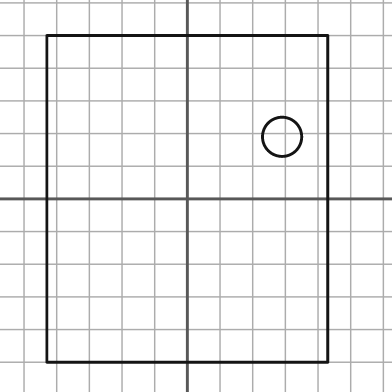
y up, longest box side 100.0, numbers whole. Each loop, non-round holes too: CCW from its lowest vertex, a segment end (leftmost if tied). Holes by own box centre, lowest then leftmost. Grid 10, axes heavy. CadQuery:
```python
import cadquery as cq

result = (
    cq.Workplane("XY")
    .moveTo(-43.0, -50.0)
    .lineTo(43.0, -50.0)
    .lineTo(43.0, 50.0)
    .lineTo(-43.0, 50.0)
    .close()
    .moveTo(29.0, 19.0)
    .circle(6.0)
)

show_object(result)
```